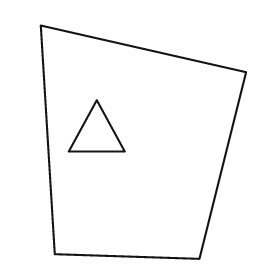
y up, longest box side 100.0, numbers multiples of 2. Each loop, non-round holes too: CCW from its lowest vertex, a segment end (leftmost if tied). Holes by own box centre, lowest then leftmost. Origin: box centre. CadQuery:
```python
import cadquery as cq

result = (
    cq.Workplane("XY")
    .moveTo(24.0, -50.0)
    .lineTo(44.0, 30.0)
    .lineTo(-44.0, 50.0)
    .lineTo(-38.0, -48.0)
    .close()
    .moveTo(-32.0, -4.0)
    .lineTo(-8.0, -4.0)
    .lineTo(-20.0, 18.0)
    .close()
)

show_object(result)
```